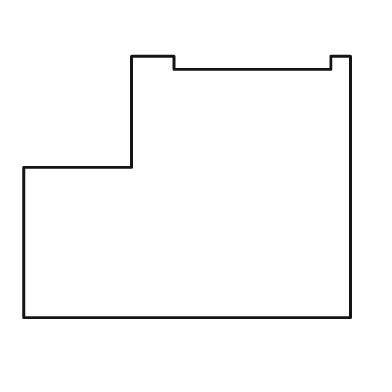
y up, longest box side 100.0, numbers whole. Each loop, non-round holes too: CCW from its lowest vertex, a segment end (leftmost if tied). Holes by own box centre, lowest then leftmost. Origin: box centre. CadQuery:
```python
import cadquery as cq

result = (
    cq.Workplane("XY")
    .moveTo(-50.0, -40.0)
    .lineTo(50.0, -40.0)
    .lineTo(50.0, 40.0)
    .lineTo(44.0, 40.0)
    .lineTo(44.0, 36.0)
    .lineTo(-4.0, 36.0)
    .lineTo(-4.0, 40.0)
    .lineTo(-17.0, 40.0)
    .lineTo(-17.0, 6.0)
    .lineTo(-50.0, 6.0)
    .close()
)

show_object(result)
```